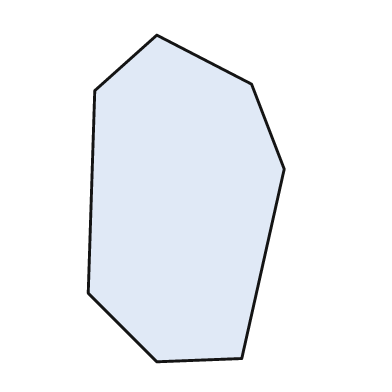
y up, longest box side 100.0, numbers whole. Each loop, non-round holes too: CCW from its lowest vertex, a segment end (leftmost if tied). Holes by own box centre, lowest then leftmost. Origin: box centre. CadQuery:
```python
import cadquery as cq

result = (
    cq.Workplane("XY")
    .moveTo(-9.0, -50.0)
    .lineTo(17.0, -49.0)
    .lineTo(30.0, 9.0)
    .lineTo(20.0, 35.0)
    .lineTo(-9.0, 50.0)
    .lineTo(-28.0, 33.0)
    .lineTo(-30.0, -29.0)
    .close()
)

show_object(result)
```